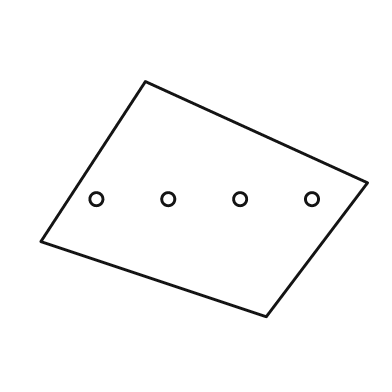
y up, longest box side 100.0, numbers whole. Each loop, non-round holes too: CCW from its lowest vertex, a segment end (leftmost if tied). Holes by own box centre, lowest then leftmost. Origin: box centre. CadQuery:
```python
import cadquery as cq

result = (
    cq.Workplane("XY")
    .moveTo(19.0, -36.0)
    .lineTo(50.0, 5.0)
    .lineTo(-18.0, 36.0)
    .lineTo(-50.0, -13.0)
    .close()
    .moveTo(-33.0, 0.0)
    .circle(2.0)
    .moveTo(-11.0, 0.0)
    .circle(2.0)
    .moveTo(11.0, 0.0)
    .circle(2.0)
    .moveTo(33.0, 0.0)
    .circle(2.0)
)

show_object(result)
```